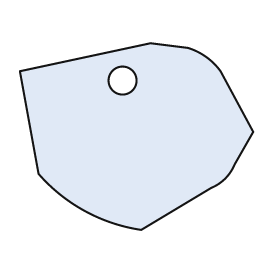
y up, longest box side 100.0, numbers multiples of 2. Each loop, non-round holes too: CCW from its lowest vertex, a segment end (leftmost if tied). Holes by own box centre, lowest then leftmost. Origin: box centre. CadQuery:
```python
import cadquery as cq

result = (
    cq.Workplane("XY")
    .moveTo(2.0, -40.0)
    .lineTo(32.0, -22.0)
    .threePointArc((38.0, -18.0), (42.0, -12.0))
    .lineTo(50.0, 2.0)
    .lineTo(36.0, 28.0)
    .threePointArc((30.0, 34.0), (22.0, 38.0))
    .lineTo(6.0, 40.0)
    .lineTo(-50.0, 28.0)
    .lineTo(-42.0, -16.0)
    .threePointArc((-22.0, -32.0), (2.0, -40.0))
    .close()
    .moveTo(-6.0, 24.0)
    .circle(6.0)
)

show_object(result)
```